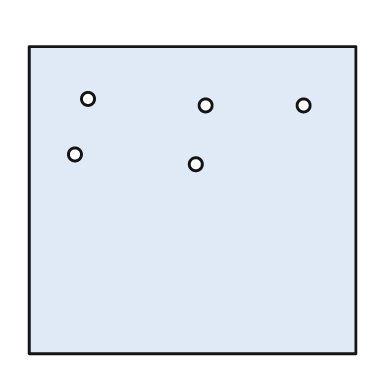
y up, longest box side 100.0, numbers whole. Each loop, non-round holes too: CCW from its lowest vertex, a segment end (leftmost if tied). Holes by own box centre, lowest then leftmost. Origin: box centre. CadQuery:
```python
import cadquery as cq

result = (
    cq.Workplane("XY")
    .moveTo(-50.0, -47.0)
    .lineTo(50.0, -47.0)
    .lineTo(50.0, 47.0)
    .lineTo(-50.0, 47.0)
    .close()
    .moveTo(1.0, 11.0)
    .circle(2.0)
    .moveTo(-36.0, 14.0)
    .circle(2.0)
    .moveTo(4.0, 29.0)
    .circle(2.0)
    .moveTo(34.0, 29.0)
    .circle(2.0)
    .moveTo(-32.0, 31.0)
    .circle(2.0)
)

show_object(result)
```